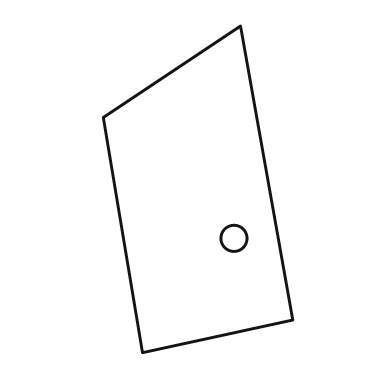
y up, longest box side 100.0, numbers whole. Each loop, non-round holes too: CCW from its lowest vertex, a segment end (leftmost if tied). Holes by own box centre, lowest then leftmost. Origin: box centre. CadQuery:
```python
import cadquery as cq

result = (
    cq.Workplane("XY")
    .moveTo(-17.0, -50.0)
    .lineTo(29.0, -40.0)
    .lineTo(13.0, 50.0)
    .lineTo(-29.0, 22.0)
    .close()
    .moveTo(11.0, -15.0)
    .circle(4.0)
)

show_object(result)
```